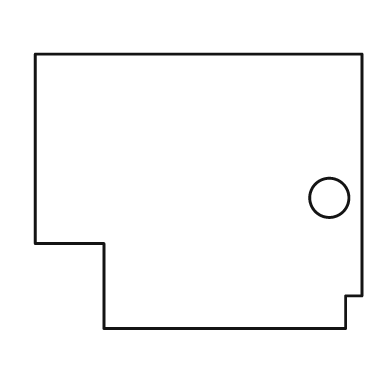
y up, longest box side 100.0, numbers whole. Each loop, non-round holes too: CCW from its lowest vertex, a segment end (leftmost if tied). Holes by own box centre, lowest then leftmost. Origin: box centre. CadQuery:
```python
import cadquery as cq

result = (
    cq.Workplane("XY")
    .moveTo(-29.0, -42.0)
    .lineTo(45.0, -42.0)
    .lineTo(45.0, -32.0)
    .lineTo(50.0, -32.0)
    .lineTo(50.0, 42.0)
    .lineTo(-50.0, 42.0)
    .lineTo(-50.0, -16.0)
    .lineTo(-29.0, -16.0)
    .close()
    .moveTo(40.0, -2.0)
    .circle(6.0)
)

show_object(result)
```